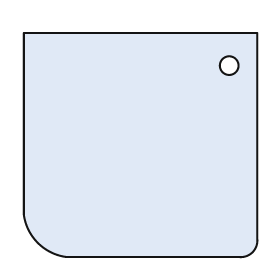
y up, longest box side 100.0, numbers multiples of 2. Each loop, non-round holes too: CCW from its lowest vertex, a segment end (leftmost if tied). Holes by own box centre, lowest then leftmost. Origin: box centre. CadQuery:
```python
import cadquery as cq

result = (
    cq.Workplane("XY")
    .moveTo(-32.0, -48.0)
    .lineTo(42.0, -48.0)
    .threePointArc((48.0, -46.0), (50.0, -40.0))
    .lineTo(50.0, 48.0)
    .lineTo(-50.0, 48.0)
    .lineTo(-50.0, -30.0)
    .threePointArc((-44.0, -42.0), (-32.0, -48.0))
    .close()
    .moveTo(38.0, 34.0)
    .circle(4.0)
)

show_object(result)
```